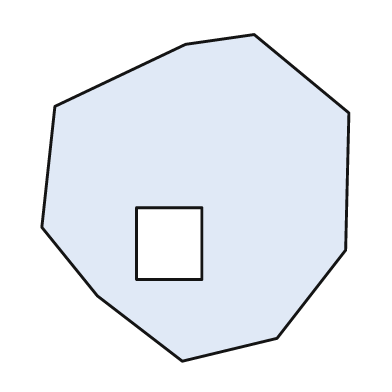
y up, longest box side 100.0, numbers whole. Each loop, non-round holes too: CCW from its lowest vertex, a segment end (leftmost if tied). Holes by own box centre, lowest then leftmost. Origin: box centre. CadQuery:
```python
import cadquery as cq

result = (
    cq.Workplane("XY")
    .moveTo(-4.0, -50.0)
    .lineTo(25.0, -43.0)
    .lineTo(46.0, -16.0)
    .lineTo(47.0, 26.0)
    .lineTo(18.0, 50.0)
    .lineTo(-3.0, 47.0)
    .lineTo(-43.0, 28.0)
    .lineTo(-47.0, -9.0)
    .lineTo(-30.0, -30.0)
    .close()
    .moveTo(-18.0, -25.0)
    .lineTo(2.0, -25.0)
    .lineTo(2.0, -3.0)
    .lineTo(-18.0, -3.0)
    .close()
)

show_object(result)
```